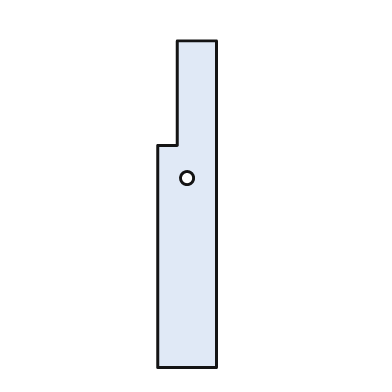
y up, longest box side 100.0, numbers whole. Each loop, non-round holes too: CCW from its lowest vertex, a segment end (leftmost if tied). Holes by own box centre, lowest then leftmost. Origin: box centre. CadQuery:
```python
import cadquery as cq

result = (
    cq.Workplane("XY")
    .moveTo(-9.0, -50.0)
    .lineTo(9.0, -50.0)
    .lineTo(9.0, 50.0)
    .lineTo(-3.0, 50.0)
    .lineTo(-3.0, 18.0)
    .lineTo(-9.0, 18.0)
    .close()
    .moveTo(0.0, 8.0)
    .circle(2.0)
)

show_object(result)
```